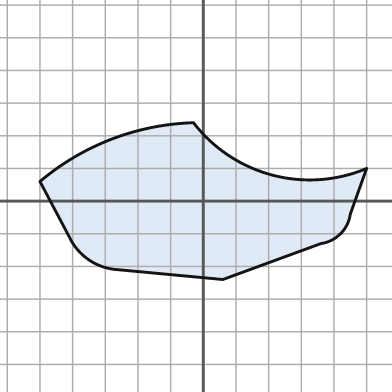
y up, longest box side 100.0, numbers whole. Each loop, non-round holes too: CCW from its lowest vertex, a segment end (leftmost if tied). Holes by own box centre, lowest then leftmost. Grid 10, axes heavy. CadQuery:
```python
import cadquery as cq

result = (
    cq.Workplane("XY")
    .moveTo(6.0, -24.0)
    .lineTo(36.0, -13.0)
    .threePointArc((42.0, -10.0), (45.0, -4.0))
    .lineTo(50.0, 10.0)
    .threePointArc((21.0, 8.0), (-3.0, 24.0))
    .threePointArc((-28.0, 19.0), (-50.0, 6.0))
    .lineTo(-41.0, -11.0)
    .threePointArc((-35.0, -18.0), (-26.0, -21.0))
    .close()
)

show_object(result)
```